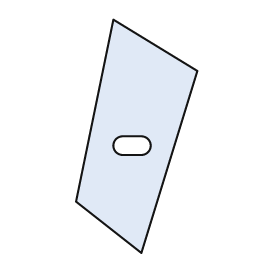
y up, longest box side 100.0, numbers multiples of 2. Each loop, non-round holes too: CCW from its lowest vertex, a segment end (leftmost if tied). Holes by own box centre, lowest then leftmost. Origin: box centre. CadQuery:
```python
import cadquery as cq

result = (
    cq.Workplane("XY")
    .moveTo(2.0, -50.0)
    .lineTo(26.0, 28.0)
    .lineTo(-10.0, 50.0)
    .lineTo(-26.0, -28.0)
    .close()
    .moveTo(-6.0, -8.0)
    .lineTo(2.0, -8.0)
    .threePointArc((6.0, -4.0), (2.0, 0.0))
    .lineTo(-6.0, 0.0)
    .threePointArc((-10.0, -4.0), (-6.0, -8.0))
    .close()
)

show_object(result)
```